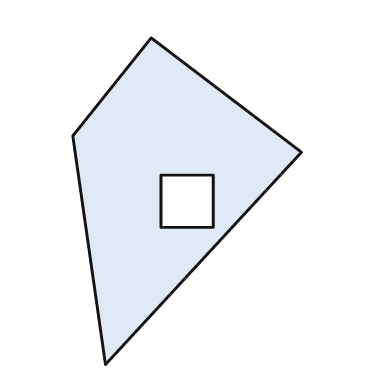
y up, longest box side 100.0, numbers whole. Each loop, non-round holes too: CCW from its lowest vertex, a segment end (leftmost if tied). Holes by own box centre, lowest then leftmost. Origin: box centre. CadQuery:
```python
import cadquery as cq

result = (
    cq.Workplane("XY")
    .moveTo(-25.0, -50.0)
    .lineTo(35.0, 15.0)
    .lineTo(-11.0, 50.0)
    .lineTo(-35.0, 20.0)
    .close()
    .moveTo(-8.0, -8.0)
    .lineTo(8.0, -8.0)
    .lineTo(8.0, 8.0)
    .lineTo(-8.0, 8.0)
    .close()
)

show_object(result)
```